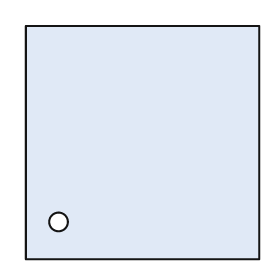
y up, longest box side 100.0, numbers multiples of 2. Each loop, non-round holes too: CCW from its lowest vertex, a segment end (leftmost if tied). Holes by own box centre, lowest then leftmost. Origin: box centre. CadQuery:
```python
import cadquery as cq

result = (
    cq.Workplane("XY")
    .moveTo(-50.0, -50.0)
    .lineTo(50.0, -50.0)
    .lineTo(50.0, 50.0)
    .lineTo(-50.0, 50.0)
    .close()
    .moveTo(-36.0, -34.0)
    .circle(4.0)
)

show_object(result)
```